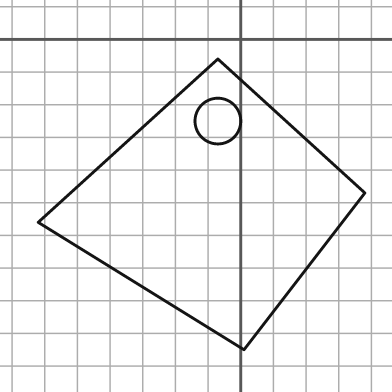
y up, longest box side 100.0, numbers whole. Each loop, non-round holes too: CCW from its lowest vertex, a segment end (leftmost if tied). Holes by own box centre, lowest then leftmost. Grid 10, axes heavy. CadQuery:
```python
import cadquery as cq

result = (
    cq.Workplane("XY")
    .moveTo(1.0, -95.0)
    .lineTo(38.0, -47.0)
    .lineTo(-7.0, -6.0)
    .lineTo(-62.0, -56.0)
    .close()
    .moveTo(-7.0, -25.0)
    .circle(7.0)
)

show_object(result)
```